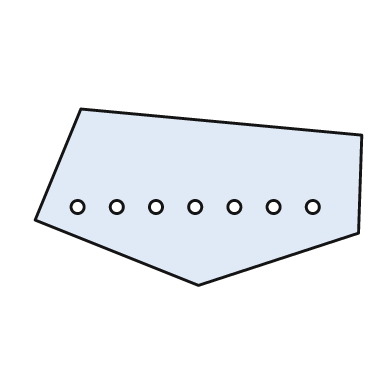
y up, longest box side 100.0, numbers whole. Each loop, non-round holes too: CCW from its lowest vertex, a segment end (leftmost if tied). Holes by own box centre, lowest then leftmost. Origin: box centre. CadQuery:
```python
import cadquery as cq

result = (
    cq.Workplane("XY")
    .moveTo(0.0, -27.0)
    .lineTo(49.0, -11.0)
    .lineTo(50.0, 19.0)
    .lineTo(-36.0, 27.0)
    .lineTo(-50.0, -7.0)
    .close()
    .moveTo(-37.0, -3.0)
    .circle(2.0)
    .moveTo(-25.0, -3.0)
    .circle(2.0)
    .moveTo(-13.0, -3.0)
    .circle(2.0)
    .moveTo(-1.0, -3.0)
    .circle(2.0)
    .moveTo(11.0, -3.0)
    .circle(2.0)
    .moveTo(23.0, -3.0)
    .circle(2.0)
    .moveTo(35.0, -3.0)
    .circle(2.0)
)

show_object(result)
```